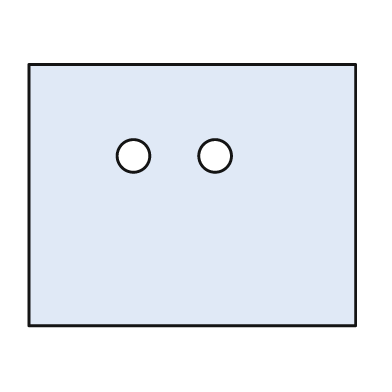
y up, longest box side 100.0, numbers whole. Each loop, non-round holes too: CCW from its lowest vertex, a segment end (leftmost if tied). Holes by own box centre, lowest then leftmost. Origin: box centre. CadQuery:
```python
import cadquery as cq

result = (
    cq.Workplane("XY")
    .moveTo(-50.0, -40.0)
    .lineTo(50.0, -40.0)
    .lineTo(50.0, 40.0)
    .lineTo(-50.0, 40.0)
    .close()
    .moveTo(-18.0, 12.0)
    .circle(5.0)
    .moveTo(7.0, 12.0)
    .circle(5.0)
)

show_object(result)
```